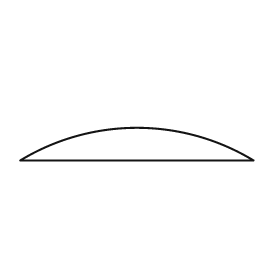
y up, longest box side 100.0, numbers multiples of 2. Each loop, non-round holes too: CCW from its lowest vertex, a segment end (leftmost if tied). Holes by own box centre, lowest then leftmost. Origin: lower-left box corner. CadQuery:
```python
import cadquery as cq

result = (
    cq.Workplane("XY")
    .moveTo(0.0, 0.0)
    .lineTo(100.0, 0.0)
    .threePointArc((50.0, 14.0), (0.0, 0.0))
    .close()
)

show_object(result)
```